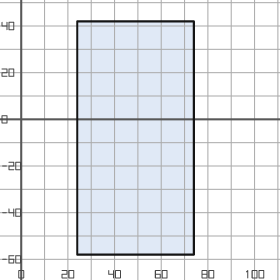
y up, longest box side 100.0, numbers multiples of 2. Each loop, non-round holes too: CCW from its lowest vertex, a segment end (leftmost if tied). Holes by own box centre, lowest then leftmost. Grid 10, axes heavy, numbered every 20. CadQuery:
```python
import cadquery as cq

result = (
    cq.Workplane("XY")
    .moveTo(24.0, -58.0)
    .lineTo(74.0, -58.0)
    .lineTo(74.0, 42.0)
    .lineTo(24.0, 42.0)
    .close()
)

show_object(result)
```